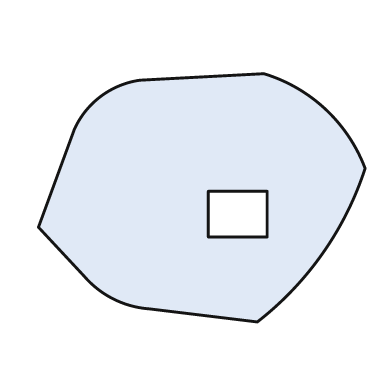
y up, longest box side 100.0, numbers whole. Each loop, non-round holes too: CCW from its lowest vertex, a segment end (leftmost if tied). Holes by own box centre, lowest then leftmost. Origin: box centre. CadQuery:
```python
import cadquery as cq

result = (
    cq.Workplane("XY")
    .moveTo(17.0, -38.0)
    .threePointArc((37.0, -17.0), (50.0, 9.0))
    .threePointArc((38.0, 27.0), (19.0, 38.0))
    .lineTo(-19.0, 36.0)
    .threePointArc((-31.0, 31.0), (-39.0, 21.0))
    .lineTo(-50.0, -9.0)
    .lineTo(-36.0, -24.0)
    .threePointArc((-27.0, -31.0), (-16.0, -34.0))
    .close()
    .moveTo(2.0, -12.0)
    .lineTo(20.0, -12.0)
    .lineTo(20.0, 2.0)
    .lineTo(2.0, 2.0)
    .close()
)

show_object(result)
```